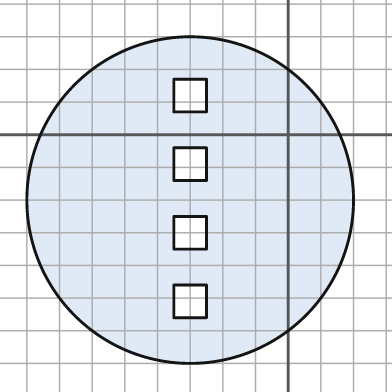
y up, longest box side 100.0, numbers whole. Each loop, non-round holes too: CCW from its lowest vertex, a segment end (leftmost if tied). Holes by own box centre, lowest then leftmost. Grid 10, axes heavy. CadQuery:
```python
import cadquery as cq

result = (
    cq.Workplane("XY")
    .moveTo(-30.0, -20.0)
    .circle(50.0)
    .moveTo(-35.0, -56.0)
    .lineTo(-25.0, -56.0)
    .lineTo(-25.0, -46.0)
    .lineTo(-35.0, -46.0)
    .close()
    .moveTo(-35.0, -35.0)
    .lineTo(-25.0, -35.0)
    .lineTo(-25.0, -25.0)
    .lineTo(-35.0, -25.0)
    .close()
    .moveTo(-35.0, -14.0)
    .lineTo(-25.0, -14.0)
    .lineTo(-25.0, -4.0)
    .lineTo(-35.0, -4.0)
    .close()
    .moveTo(-35.0, 7.0)
    .lineTo(-25.0, 7.0)
    .lineTo(-25.0, 17.0)
    .lineTo(-35.0, 17.0)
    .close()
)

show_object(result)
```